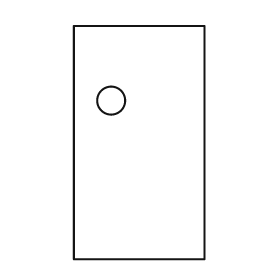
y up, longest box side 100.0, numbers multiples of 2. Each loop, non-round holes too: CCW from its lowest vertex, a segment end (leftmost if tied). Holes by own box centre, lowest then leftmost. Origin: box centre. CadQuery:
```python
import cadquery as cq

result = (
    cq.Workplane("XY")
    .moveTo(-28.0, -50.0)
    .lineTo(28.0, -50.0)
    .lineTo(28.0, 50.0)
    .lineTo(-28.0, 50.0)
    .close()
    .moveTo(-12.0, 18.0)
    .circle(6.0)
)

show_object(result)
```